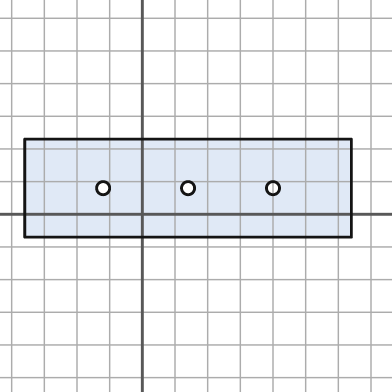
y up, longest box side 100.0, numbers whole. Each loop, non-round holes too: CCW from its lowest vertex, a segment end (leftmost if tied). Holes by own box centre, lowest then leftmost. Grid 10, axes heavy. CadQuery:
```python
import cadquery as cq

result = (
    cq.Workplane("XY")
    .moveTo(-36.0, -7.0)
    .lineTo(64.0, -7.0)
    .lineTo(64.0, 23.0)
    .lineTo(-36.0, 23.0)
    .close()
    .moveTo(-12.0, 8.0)
    .circle(2.0)
    .moveTo(14.0, 8.0)
    .circle(2.0)
    .moveTo(40.0, 8.0)
    .circle(2.0)
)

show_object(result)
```